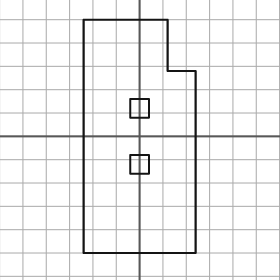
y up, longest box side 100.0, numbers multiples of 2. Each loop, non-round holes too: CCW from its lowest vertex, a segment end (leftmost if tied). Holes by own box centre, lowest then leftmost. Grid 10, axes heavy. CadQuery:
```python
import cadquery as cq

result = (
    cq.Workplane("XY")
    .moveTo(-24.0, -50.0)
    .lineTo(24.0, -50.0)
    .lineTo(24.0, 28.0)
    .lineTo(12.0, 28.0)
    .lineTo(12.0, 50.0)
    .lineTo(-24.0, 50.0)
    .close()
    .moveTo(-4.0, -16.0)
    .lineTo(4.0, -16.0)
    .lineTo(4.0, -8.0)
    .lineTo(-4.0, -8.0)
    .close()
    .moveTo(-4.0, 8.0)
    .lineTo(4.0, 8.0)
    .lineTo(4.0, 16.0)
    .lineTo(-4.0, 16.0)
    .close()
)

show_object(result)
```